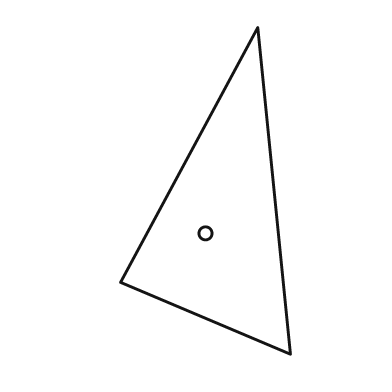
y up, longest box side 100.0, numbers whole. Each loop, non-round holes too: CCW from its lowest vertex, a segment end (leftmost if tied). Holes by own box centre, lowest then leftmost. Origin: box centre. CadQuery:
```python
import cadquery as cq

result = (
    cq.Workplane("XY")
    .moveTo(26.0, -50.0)
    .lineTo(16.0, 50.0)
    .lineTo(-26.0, -28.0)
    .close()
    .moveTo(0.0, -13.0)
    .circle(2.0)
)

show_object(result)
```